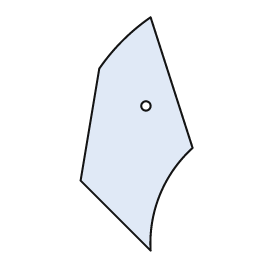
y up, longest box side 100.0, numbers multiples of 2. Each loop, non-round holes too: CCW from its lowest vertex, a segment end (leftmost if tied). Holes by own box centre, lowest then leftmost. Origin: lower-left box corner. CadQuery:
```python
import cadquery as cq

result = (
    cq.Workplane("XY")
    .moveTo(30.0, 0.0)
    .threePointArc((34.0, 24.0), (48.0, 44.0))
    .lineTo(30.0, 100.0)
    .threePointArc((18.0, 90.0), (8.0, 78.0))
    .lineTo(0.0, 30.0)
    .close()
    .moveTo(28.0, 62.0)
    .circle(2.0)
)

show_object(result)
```